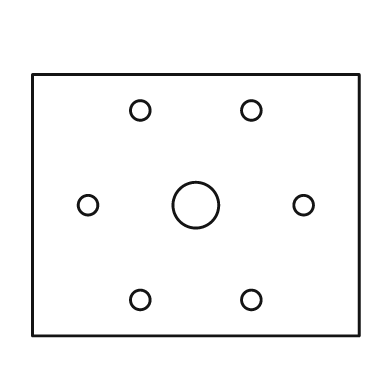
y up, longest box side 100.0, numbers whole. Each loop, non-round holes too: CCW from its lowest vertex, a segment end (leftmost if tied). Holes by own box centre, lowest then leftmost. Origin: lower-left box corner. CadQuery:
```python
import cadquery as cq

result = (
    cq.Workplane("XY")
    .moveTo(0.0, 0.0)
    .lineTo(100.0, 0.0)
    .lineTo(100.0, 80.0)
    .lineTo(0.0, 80.0)
    .close()
    .moveTo(33.0, 11.0)
    .circle(3.0)
    .moveTo(67.0, 11.0)
    .circle(3.0)
    .moveTo(17.0, 40.0)
    .circle(3.0)
    .moveTo(50.0, 40.0)
    .circle(7.0)
    .moveTo(83.0, 40.0)
    .circle(3.0)
    .moveTo(33.0, 69.0)
    .circle(3.0)
    .moveTo(67.0, 69.0)
    .circle(3.0)
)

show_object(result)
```